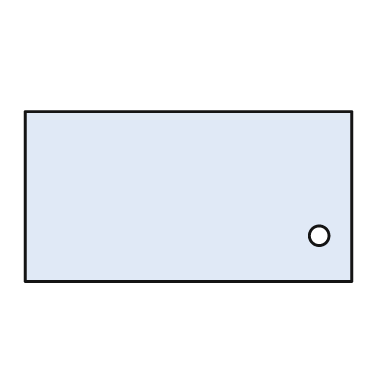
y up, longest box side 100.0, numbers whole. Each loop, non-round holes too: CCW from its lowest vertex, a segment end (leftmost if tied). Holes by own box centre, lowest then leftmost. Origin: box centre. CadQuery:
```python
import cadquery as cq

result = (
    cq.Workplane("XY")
    .moveTo(-50.0, -26.0)
    .lineTo(50.0, -26.0)
    .lineTo(50.0, 26.0)
    .lineTo(-50.0, 26.0)
    .close()
    .moveTo(40.0, -12.0)
    .circle(3.0)
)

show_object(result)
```